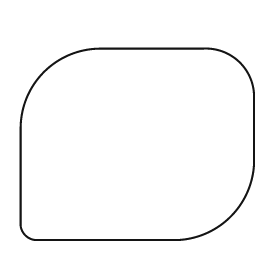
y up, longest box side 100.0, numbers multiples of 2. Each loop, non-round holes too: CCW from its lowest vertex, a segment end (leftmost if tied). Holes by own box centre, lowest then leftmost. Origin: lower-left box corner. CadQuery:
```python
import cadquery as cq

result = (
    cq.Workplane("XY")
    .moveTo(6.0, 0.0)
    .lineTo(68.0, 0.0)
    .threePointArc((90.0, 10.0), (100.0, 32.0))
    .lineTo(100.0, 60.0)
    .threePointArc((94.0, 76.0), (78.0, 82.0))
    .lineTo(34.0, 82.0)
    .threePointArc((10.0, 72.0), (0.0, 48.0))
    .lineTo(0.0, 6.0)
    .threePointArc((2.0, 2.0), (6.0, 0.0))
    .close()
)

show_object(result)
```